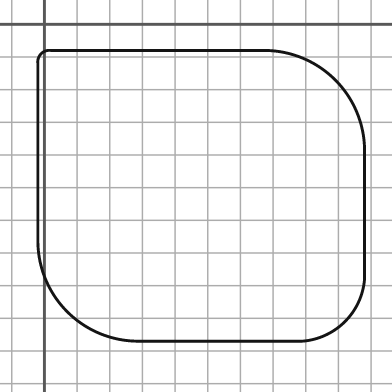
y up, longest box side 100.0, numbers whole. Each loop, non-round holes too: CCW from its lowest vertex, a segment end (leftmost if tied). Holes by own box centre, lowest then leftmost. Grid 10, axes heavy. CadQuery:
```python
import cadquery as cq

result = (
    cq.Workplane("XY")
    .moveTo(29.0, -97.0)
    .lineTo(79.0, -97.0)
    .threePointArc((92.0, -91.0), (98.0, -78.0))
    .lineTo(98.0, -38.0)
    .threePointArc((89.0, -17.0), (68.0, -8.0))
    .lineTo(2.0, -8.0)
    .threePointArc((-1.0, -9.0), (-2.0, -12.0))
    .lineTo(-2.0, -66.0)
    .threePointArc((7.0, -88.0), (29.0, -97.0))
    .close()
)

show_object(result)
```